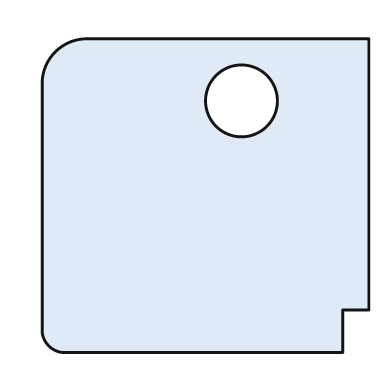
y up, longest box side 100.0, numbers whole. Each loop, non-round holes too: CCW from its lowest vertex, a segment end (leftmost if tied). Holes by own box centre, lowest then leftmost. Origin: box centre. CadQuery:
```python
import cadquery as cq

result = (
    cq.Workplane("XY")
    .moveTo(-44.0, -48.0)
    .lineTo(42.0, -48.0)
    .lineTo(42.0, -35.0)
    .lineTo(50.0, -35.0)
    .lineTo(50.0, 48.0)
    .lineTo(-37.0, 48.0)
    .threePointArc((-46.0, 44.0), (-50.0, 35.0))
    .lineTo(-50.0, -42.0)
    .threePointArc((-48.0, -46.0), (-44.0, -48.0))
    .close()
    .moveTo(11.0, 29.0)
    .circle(11.0)
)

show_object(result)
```